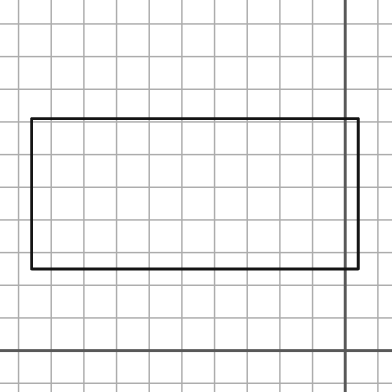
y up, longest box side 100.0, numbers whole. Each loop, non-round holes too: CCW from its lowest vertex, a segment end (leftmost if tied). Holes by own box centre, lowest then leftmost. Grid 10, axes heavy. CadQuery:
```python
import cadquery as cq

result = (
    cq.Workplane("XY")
    .moveTo(-96.0, 25.0)
    .lineTo(4.0, 25.0)
    .lineTo(4.0, 71.0)
    .lineTo(-96.0, 71.0)
    .close()
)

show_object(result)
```